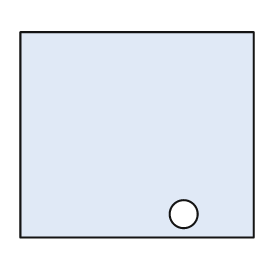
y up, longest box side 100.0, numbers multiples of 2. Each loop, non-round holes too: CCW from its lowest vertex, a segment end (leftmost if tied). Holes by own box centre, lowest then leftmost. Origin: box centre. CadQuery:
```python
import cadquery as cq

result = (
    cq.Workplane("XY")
    .moveTo(-50.0, -44.0)
    .lineTo(50.0, -44.0)
    .lineTo(50.0, 44.0)
    .lineTo(-50.0, 44.0)
    .close()
    .moveTo(20.0, -34.0)
    .circle(6.0)
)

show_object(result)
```